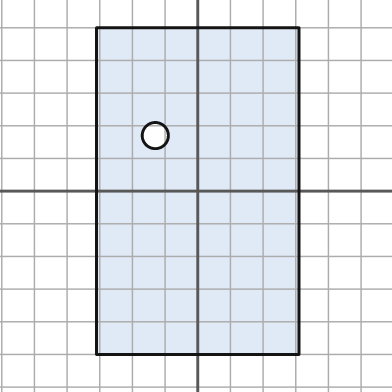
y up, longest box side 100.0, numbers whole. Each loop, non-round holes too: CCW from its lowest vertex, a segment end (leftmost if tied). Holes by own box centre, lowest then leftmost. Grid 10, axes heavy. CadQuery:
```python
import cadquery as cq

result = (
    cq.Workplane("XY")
    .moveTo(-31.0, -50.0)
    .lineTo(31.0, -50.0)
    .lineTo(31.0, 50.0)
    .lineTo(-31.0, 50.0)
    .close()
    .moveTo(-13.0, 17.0)
    .circle(4.0)
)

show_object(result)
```